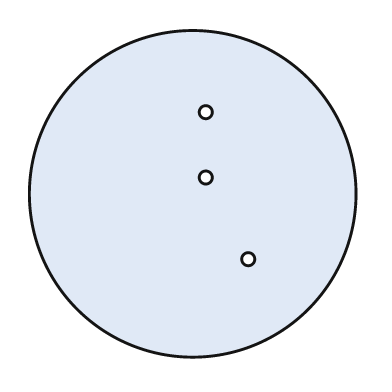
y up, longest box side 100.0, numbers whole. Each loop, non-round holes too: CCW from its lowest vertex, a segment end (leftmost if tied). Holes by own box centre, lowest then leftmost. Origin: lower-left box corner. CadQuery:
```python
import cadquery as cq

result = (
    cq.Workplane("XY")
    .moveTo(50.0, 50.0)
    .circle(50.0)
    .moveTo(67.0, 30.0)
    .circle(2.0)
    .moveTo(54.0, 55.0)
    .circle(2.0)
    .moveTo(54.0, 75.0)
    .circle(2.0)
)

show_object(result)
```